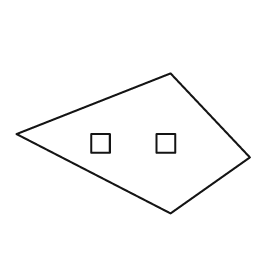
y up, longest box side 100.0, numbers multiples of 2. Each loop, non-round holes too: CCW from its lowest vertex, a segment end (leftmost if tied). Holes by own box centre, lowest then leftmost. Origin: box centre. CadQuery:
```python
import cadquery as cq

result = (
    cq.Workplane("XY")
    .moveTo(16.0, -30.0)
    .lineTo(50.0, -6.0)
    .lineTo(16.0, 30.0)
    .lineTo(-50.0, 4.0)
    .close()
    .moveTo(-18.0, -4.0)
    .lineTo(-10.0, -4.0)
    .lineTo(-10.0, 4.0)
    .lineTo(-18.0, 4.0)
    .close()
    .moveTo(10.0, -4.0)
    .lineTo(18.0, -4.0)
    .lineTo(18.0, 4.0)
    .lineTo(10.0, 4.0)
    .close()
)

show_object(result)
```